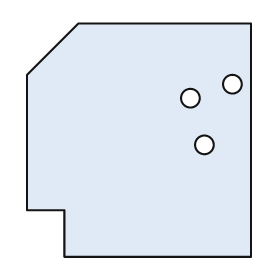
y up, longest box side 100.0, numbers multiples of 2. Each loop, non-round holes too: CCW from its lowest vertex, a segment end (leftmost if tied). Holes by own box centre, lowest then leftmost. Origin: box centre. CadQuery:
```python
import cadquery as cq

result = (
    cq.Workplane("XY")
    .moveTo(-32.0, -50.0)
    .lineTo(48.0, -50.0)
    .lineTo(48.0, 50.0)
    .lineTo(-26.0, 50.0)
    .lineTo(-48.0, 28.0)
    .lineTo(-48.0, -30.0)
    .lineTo(-32.0, -30.0)
    .close()
    .moveTo(28.0, -2.0)
    .circle(4.0)
    .moveTo(22.0, 18.0)
    .circle(4.0)
    .moveTo(40.0, 24.0)
    .circle(4.0)
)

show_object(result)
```